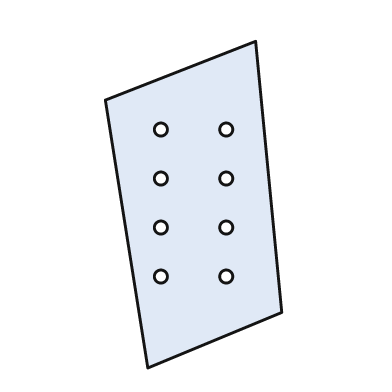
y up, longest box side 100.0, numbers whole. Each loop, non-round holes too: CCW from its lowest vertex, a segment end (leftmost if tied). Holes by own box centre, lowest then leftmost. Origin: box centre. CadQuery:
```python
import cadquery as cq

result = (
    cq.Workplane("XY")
    .moveTo(-14.0, -50.0)
    .lineTo(27.0, -33.0)
    .lineTo(19.0, 50.0)
    .lineTo(-27.0, 32.0)
    .close()
    .moveTo(-10.0, -22.0)
    .circle(2.0)
    .moveTo(10.0, -22.0)
    .circle(2.0)
    .moveTo(-10.0, -7.0)
    .circle(2.0)
    .moveTo(10.0, -7.0)
    .circle(2.0)
    .moveTo(-10.0, 8.0)
    .circle(2.0)
    .moveTo(10.0, 8.0)
    .circle(2.0)
    .moveTo(-10.0, 23.0)
    .circle(2.0)
    .moveTo(10.0, 23.0)
    .circle(2.0)
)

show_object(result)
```